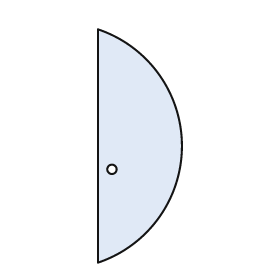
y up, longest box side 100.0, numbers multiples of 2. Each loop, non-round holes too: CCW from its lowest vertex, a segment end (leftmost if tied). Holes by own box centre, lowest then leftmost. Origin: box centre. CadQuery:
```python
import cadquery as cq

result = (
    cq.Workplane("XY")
    .moveTo(-18.0, -50.0)
    .threePointArc((18.0, 0.0), (-18.0, 50.0))
    .close()
    .moveTo(-12.0, -10.0)
    .circle(2.0)
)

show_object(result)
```